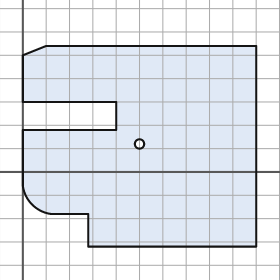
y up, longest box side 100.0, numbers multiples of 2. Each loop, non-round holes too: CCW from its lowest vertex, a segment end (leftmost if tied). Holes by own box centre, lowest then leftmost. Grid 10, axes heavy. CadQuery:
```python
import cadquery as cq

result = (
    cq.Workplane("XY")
    .moveTo(28.0, -32.0)
    .lineTo(100.0, -32.0)
    .lineTo(100.0, 54.0)
    .lineTo(10.0, 54.0)
    .lineTo(0.0, 50.0)
    .lineTo(0.0, 30.0)
    .lineTo(40.0, 30.0)
    .lineTo(40.0, 18.0)
    .lineTo(0.0, 18.0)
    .lineTo(0.0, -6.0)
    .threePointArc((4.0, -14.0), (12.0, -18.0))
    .lineTo(28.0, -18.0)
    .close()
    .moveTo(50.0, 12.0)
    .circle(2.0)
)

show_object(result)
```